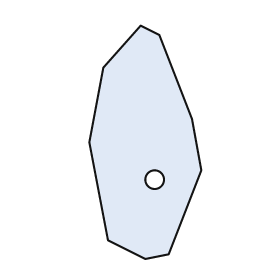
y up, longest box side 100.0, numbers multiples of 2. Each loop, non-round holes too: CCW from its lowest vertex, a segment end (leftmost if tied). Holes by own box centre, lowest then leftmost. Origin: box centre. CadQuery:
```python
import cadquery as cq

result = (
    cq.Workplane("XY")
    .moveTo(0.0, -50.0)
    .lineTo(10.0, -48.0)
    .lineTo(24.0, -12.0)
    .lineTo(20.0, 10.0)
    .lineTo(6.0, 46.0)
    .lineTo(-2.0, 50.0)
    .lineTo(-18.0, 32.0)
    .lineTo(-24.0, 0.0)
    .lineTo(-16.0, -42.0)
    .close()
    .moveTo(4.0, -16.0)
    .circle(4.0)
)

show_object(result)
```